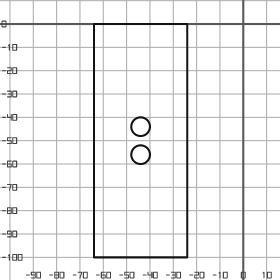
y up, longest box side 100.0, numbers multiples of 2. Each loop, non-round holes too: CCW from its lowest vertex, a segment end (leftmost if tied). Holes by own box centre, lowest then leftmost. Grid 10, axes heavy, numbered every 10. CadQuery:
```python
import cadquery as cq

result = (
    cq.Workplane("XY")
    .moveTo(-64.0, -100.0)
    .lineTo(-24.0, -100.0)
    .lineTo(-24.0, 0.0)
    .lineTo(-64.0, 0.0)
    .close()
    .moveTo(-44.0, -56.0)
    .circle(4.0)
    .moveTo(-44.0, -44.0)
    .circle(4.0)
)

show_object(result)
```